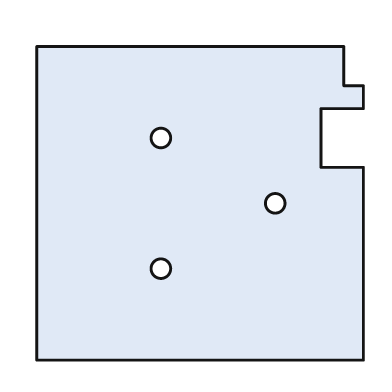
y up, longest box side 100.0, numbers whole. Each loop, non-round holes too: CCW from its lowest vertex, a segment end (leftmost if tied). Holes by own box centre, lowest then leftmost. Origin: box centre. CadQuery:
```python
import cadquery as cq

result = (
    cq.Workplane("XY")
    .moveTo(-50.0, -48.0)
    .lineTo(50.0, -48.0)
    .lineTo(50.0, 11.0)
    .lineTo(37.0, 11.0)
    .lineTo(37.0, 29.0)
    .lineTo(50.0, 29.0)
    .lineTo(50.0, 36.0)
    .lineTo(44.0, 36.0)
    .lineTo(44.0, 48.0)
    .lineTo(-50.0, 48.0)
    .close()
    .moveTo(-12.0, -20.0)
    .circle(3.0)
    .moveTo(23.0, 0.0)
    .circle(3.0)
    .moveTo(-12.0, 20.0)
    .circle(3.0)
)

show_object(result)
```